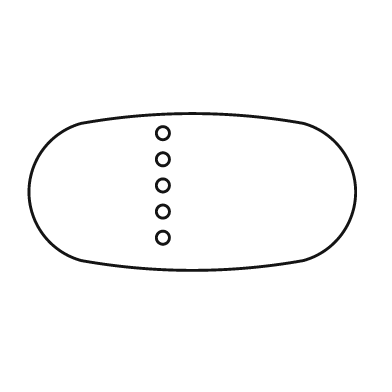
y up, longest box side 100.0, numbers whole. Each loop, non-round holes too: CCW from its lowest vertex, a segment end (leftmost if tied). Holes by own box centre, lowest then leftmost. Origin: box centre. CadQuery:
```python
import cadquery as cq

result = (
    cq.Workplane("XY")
    .moveTo(-34.0, -21.0)
    .threePointArc((0.0, -24.0), (34.0, -21.0))
    .threePointArc((50.0, 0.0), (34.0, 21.0))
    .threePointArc((0.0, 24.0), (-34.0, 21.0))
    .threePointArc((-50.0, 0.0), (-34.0, -21.0))
    .close()
    .moveTo(-9.0, -14.0)
    .circle(2.0)
    .moveTo(-9.0, -6.0)
    .circle(2.0)
    .moveTo(-9.0, 2.0)
    .circle(2.0)
    .moveTo(-9.0, 10.0)
    .circle(2.0)
    .moveTo(-9.0, 18.0)
    .circle(2.0)
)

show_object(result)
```